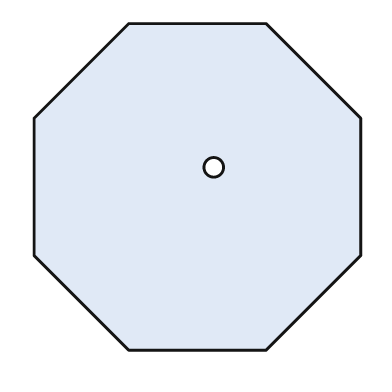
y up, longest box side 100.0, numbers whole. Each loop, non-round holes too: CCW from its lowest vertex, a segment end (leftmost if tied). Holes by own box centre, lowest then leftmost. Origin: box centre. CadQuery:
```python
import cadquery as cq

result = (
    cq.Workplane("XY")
    .moveTo(-21.0, -50.0)
    .lineTo(21.0, -50.0)
    .lineTo(50.0, -21.0)
    .lineTo(50.0, 21.0)
    .lineTo(21.0, 50.0)
    .lineTo(-21.0, 50.0)
    .lineTo(-50.0, 21.0)
    .lineTo(-50.0, -21.0)
    .close()
    .moveTo(5.0, 6.0)
    .circle(3.0)
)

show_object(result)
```